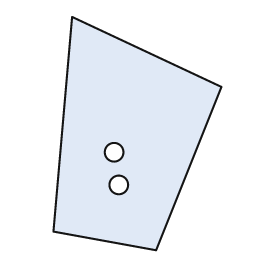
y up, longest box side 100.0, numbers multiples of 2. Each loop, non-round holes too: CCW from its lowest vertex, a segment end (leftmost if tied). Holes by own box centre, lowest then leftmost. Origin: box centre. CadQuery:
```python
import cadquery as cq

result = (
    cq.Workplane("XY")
    .moveTo(8.0, -50.0)
    .lineTo(36.0, 20.0)
    .lineTo(-28.0, 50.0)
    .lineTo(-36.0, -42.0)
    .close()
    .moveTo(-8.0, -22.0)
    .circle(4.0)
    .moveTo(-10.0, -8.0)
    .circle(4.0)
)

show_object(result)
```